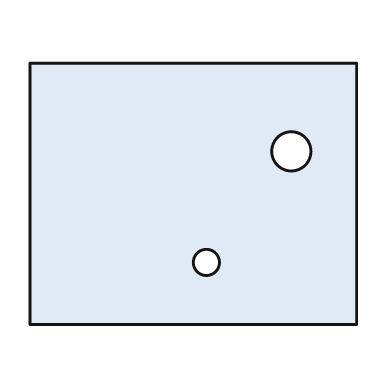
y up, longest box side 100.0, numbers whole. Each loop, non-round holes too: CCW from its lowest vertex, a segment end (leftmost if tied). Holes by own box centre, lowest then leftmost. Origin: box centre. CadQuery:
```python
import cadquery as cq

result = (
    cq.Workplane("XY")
    .moveTo(-50.0, -40.0)
    .lineTo(50.0, -40.0)
    .lineTo(50.0, 40.0)
    .lineTo(-50.0, 40.0)
    .close()
    .moveTo(4.0, -21.0)
    .circle(4.0)
    .moveTo(30.0, 13.0)
    .circle(6.0)
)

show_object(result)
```